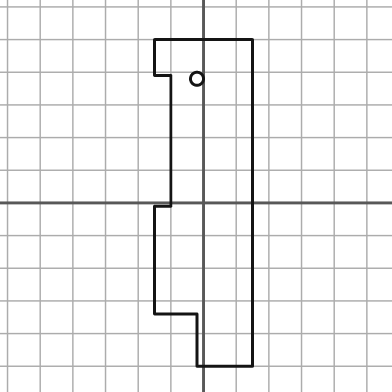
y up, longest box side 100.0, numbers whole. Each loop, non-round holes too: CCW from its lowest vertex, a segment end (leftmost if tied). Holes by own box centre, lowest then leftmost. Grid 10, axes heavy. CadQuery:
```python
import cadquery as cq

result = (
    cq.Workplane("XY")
    .moveTo(-2.0, -50.0)
    .lineTo(15.0, -50.0)
    .lineTo(15.0, 50.0)
    .lineTo(-15.0, 50.0)
    .lineTo(-15.0, 39.0)
    .lineTo(-10.0, 39.0)
    .lineTo(-10.0, -1.0)
    .lineTo(-15.0, -1.0)
    .lineTo(-15.0, -34.0)
    .lineTo(-2.0, -34.0)
    .close()
    .moveTo(-2.0, 38.0)
    .circle(2.0)
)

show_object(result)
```